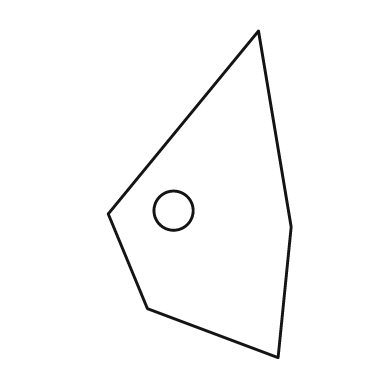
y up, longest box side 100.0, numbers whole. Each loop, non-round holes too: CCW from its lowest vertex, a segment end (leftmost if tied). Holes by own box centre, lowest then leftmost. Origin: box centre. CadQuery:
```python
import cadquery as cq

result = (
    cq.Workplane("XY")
    .moveTo(24.0, -50.0)
    .lineTo(28.0, -10.0)
    .lineTo(18.0, 50.0)
    .lineTo(-28.0, -6.0)
    .lineTo(-16.0, -35.0)
    .close()
    .moveTo(-8.0, -5.0)
    .circle(6.0)
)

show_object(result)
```